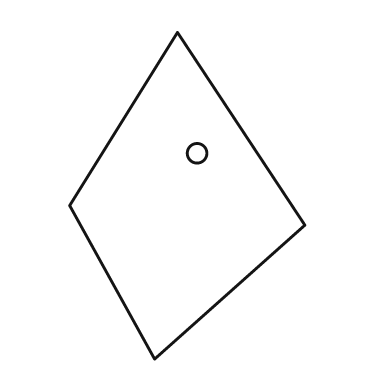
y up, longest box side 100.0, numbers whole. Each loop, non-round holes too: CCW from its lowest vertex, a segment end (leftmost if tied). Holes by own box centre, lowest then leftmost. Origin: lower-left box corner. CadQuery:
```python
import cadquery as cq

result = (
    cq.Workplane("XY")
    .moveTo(26.0, 0.0)
    .lineTo(72.0, 41.0)
    .lineTo(33.0, 100.0)
    .lineTo(0.0, 47.0)
    .close()
    .moveTo(39.0, 63.0)
    .circle(3.0)
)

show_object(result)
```